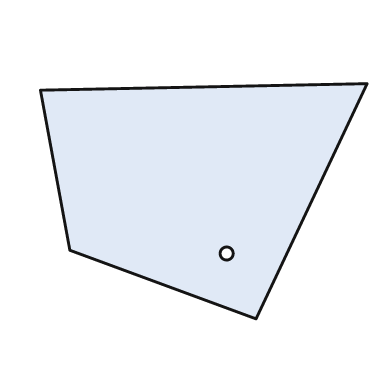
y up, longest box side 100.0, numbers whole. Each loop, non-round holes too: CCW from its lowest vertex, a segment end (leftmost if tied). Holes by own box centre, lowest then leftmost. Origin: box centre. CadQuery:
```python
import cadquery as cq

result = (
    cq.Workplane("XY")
    .moveTo(16.0, -36.0)
    .lineTo(50.0, 36.0)
    .lineTo(-50.0, 34.0)
    .lineTo(-41.0, -15.0)
    .close()
    .moveTo(7.0, -16.0)
    .circle(2.0)
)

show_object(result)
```